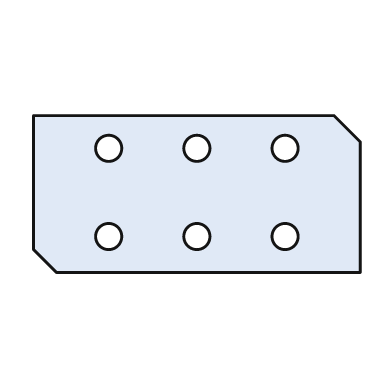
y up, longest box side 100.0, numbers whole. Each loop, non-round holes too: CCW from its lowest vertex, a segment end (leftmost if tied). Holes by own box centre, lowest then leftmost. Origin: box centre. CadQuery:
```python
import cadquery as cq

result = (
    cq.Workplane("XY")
    .moveTo(-43.0, -24.0)
    .lineTo(50.0, -24.0)
    .lineTo(50.0, 16.0)
    .lineTo(42.0, 24.0)
    .lineTo(-50.0, 24.0)
    .lineTo(-50.0, -17.0)
    .close()
    .moveTo(-27.0, -13.0)
    .circle(4.0)
    .moveTo(0.0, -13.0)
    .circle(4.0)
    .moveTo(27.0, -13.0)
    .circle(4.0)
    .moveTo(-27.0, 14.0)
    .circle(4.0)
    .moveTo(0.0, 14.0)
    .circle(4.0)
    .moveTo(27.0, 14.0)
    .circle(4.0)
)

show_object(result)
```